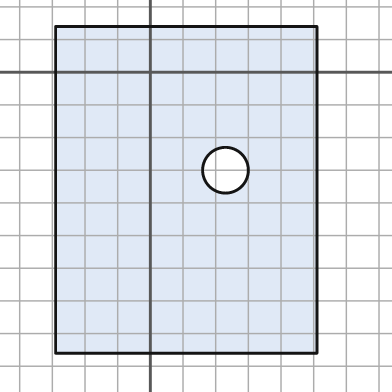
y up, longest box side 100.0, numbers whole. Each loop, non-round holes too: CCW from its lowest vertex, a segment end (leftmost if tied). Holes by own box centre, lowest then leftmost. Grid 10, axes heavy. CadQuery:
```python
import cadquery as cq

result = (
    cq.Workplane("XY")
    .moveTo(-29.0, -86.0)
    .lineTo(51.0, -86.0)
    .lineTo(51.0, 14.0)
    .lineTo(-29.0, 14.0)
    .close()
    .moveTo(23.0, -30.0)
    .circle(7.0)
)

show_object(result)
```